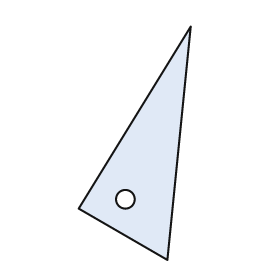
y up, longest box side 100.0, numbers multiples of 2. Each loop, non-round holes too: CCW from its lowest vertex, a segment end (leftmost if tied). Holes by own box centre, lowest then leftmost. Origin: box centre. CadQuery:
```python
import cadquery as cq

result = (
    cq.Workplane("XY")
    .moveTo(14.0, -50.0)
    .lineTo(24.0, 50.0)
    .lineTo(-24.0, -28.0)
    .close()
    .moveTo(-4.0, -24.0)
    .circle(4.0)
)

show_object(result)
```